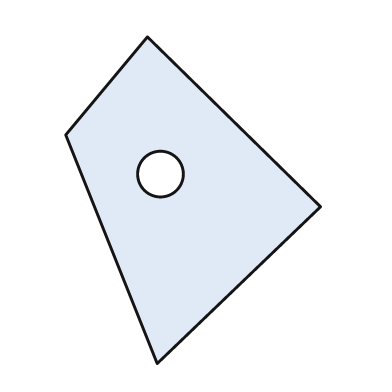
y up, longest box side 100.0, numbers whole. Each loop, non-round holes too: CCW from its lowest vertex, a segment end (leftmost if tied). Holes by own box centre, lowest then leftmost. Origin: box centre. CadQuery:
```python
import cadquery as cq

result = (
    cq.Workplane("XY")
    .moveTo(-11.0, -50.0)
    .lineTo(39.0, -2.0)
    .lineTo(-14.0, 50.0)
    .lineTo(-39.0, 20.0)
    .close()
    .moveTo(-10.0, 8.0)
    .circle(7.0)
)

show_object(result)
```